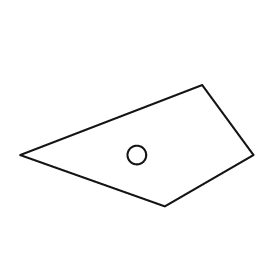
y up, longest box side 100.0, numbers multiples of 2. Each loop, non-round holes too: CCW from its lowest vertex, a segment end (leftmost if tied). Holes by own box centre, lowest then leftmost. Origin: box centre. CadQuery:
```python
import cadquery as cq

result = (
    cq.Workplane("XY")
    .moveTo(12.0, -26.0)
    .lineTo(50.0, -4.0)
    .lineTo(28.0, 26.0)
    .lineTo(-50.0, -4.0)
    .close()
    .moveTo(0.0, -4.0)
    .circle(4.0)
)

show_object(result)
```